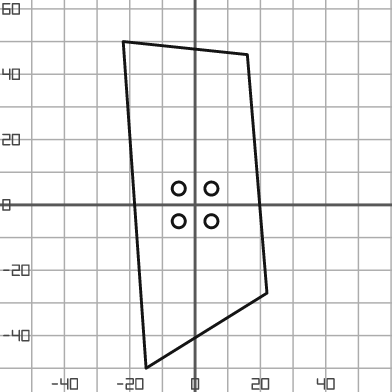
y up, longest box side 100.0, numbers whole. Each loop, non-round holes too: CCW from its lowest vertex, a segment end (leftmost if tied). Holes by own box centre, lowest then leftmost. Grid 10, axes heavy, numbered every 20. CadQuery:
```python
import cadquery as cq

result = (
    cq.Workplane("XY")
    .moveTo(-15.0, -50.0)
    .lineTo(22.0, -27.0)
    .lineTo(16.0, 46.0)
    .lineTo(-22.0, 50.0)
    .close()
    .moveTo(-5.0, -5.0)
    .circle(2.0)
    .moveTo(5.0, -5.0)
    .circle(2.0)
    .moveTo(-5.0, 5.0)
    .circle(2.0)
    .moveTo(5.0, 5.0)
    .circle(2.0)
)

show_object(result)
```